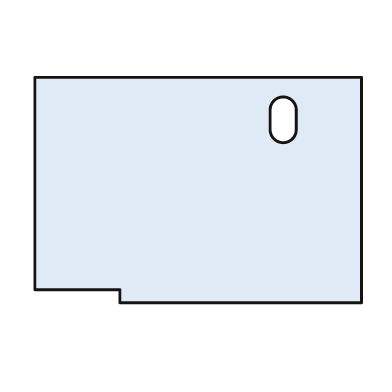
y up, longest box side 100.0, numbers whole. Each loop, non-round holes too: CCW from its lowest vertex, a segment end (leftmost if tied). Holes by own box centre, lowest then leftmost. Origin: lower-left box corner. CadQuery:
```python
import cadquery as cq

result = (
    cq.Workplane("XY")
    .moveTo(26.0, 0.0)
    .lineTo(100.0, 0.0)
    .lineTo(100.0, 69.0)
    .lineTo(0.0, 69.0)
    .lineTo(0.0, 4.0)
    .lineTo(26.0, 4.0)
    .close()
    .moveTo(72.0, 53.0)
    .threePointArc((76.0, 49.0), (80.0, 53.0))
    .lineTo(80.0, 59.0)
    .threePointArc((76.0, 63.0), (72.0, 59.0))
    .close()
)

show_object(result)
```